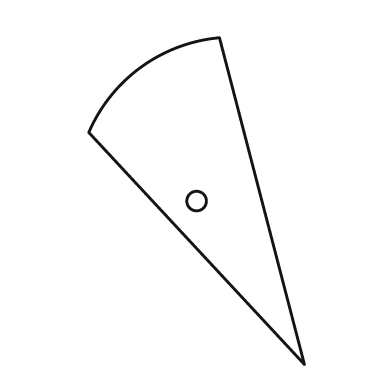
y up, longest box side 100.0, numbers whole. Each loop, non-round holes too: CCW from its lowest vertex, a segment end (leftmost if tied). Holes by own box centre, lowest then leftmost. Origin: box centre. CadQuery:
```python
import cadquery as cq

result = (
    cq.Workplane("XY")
    .moveTo(33.0, -50.0)
    .lineTo(7.0, 50.0)
    .threePointArc((-17.0, 41.0), (-33.0, 21.0))
    .close()
    .moveTo(0.0, 0.0)
    .circle(3.0)
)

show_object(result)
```